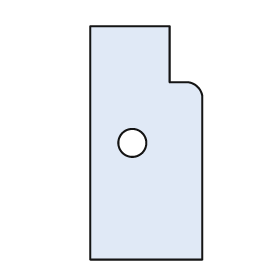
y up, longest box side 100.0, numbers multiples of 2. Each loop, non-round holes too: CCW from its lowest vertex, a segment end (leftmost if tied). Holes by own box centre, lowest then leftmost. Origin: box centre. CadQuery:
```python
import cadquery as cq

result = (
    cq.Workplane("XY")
    .moveTo(-24.0, -50.0)
    .lineTo(24.0, -50.0)
    .lineTo(24.0, 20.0)
    .threePointArc((22.0, 24.0), (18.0, 26.0))
    .lineTo(10.0, 26.0)
    .lineTo(10.0, 50.0)
    .lineTo(-24.0, 50.0)
    .close()
    .moveTo(-6.0, 0.0)
    .circle(6.0)
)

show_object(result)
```